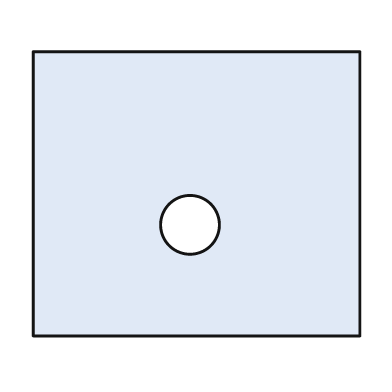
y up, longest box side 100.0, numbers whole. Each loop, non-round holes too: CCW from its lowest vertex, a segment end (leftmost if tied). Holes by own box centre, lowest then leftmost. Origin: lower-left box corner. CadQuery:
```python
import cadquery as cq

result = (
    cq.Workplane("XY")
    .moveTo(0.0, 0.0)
    .lineTo(100.0, 0.0)
    .lineTo(100.0, 87.0)
    .lineTo(0.0, 87.0)
    .close()
    .moveTo(48.0, 34.0)
    .circle(9.0)
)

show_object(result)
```